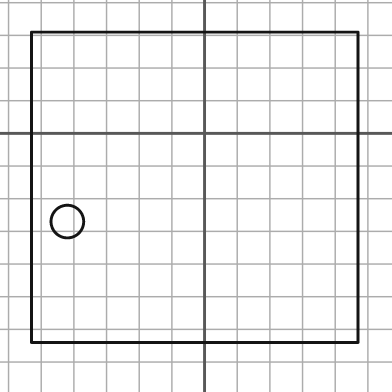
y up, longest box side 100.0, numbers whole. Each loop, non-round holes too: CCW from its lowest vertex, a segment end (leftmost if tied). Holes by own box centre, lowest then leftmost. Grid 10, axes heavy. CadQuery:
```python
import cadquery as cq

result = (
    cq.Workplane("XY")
    .moveTo(-53.0, -64.0)
    .lineTo(47.0, -64.0)
    .lineTo(47.0, 31.0)
    .lineTo(-53.0, 31.0)
    .close()
    .moveTo(-42.0, -27.0)
    .circle(5.0)
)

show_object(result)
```